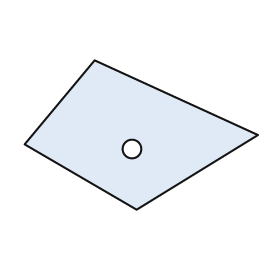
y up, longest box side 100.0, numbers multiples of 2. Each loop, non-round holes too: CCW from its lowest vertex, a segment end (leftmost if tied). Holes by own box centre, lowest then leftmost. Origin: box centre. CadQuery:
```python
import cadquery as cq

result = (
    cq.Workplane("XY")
    .moveTo(-2.0, -32.0)
    .lineTo(50.0, 0.0)
    .lineTo(-20.0, 32.0)
    .lineTo(-50.0, -4.0)
    .close()
    .moveTo(-4.0, -6.0)
    .circle(4.0)
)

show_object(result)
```